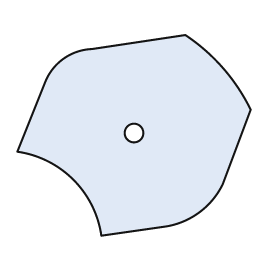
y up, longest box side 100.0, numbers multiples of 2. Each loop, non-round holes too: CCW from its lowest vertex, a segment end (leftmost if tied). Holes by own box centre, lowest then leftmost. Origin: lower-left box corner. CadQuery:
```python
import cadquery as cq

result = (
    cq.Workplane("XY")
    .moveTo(36.0, 0.0)
    .lineTo(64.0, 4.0)
    .threePointArc((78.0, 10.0), (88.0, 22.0))
    .lineTo(100.0, 54.0)
    .threePointArc((88.0, 72.0), (72.0, 86.0))
    .lineTo(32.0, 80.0)
    .threePointArc((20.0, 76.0), (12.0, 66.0))
    .lineTo(0.0, 36.0)
    .threePointArc((24.0, 24.0), (36.0, 0.0))
    .close()
    .moveTo(50.0, 44.0)
    .circle(4.0)
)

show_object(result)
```